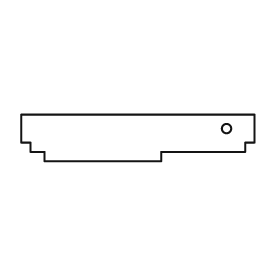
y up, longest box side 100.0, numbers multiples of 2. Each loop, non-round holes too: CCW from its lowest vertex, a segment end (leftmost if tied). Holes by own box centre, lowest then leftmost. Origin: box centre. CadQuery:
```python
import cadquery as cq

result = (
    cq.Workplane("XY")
    .moveTo(-40.0, -10.0)
    .lineTo(10.0, -10.0)
    .lineTo(10.0, -6.0)
    .lineTo(46.0, -6.0)
    .lineTo(46.0, -2.0)
    .lineTo(50.0, -2.0)
    .lineTo(50.0, 10.0)
    .lineTo(-50.0, 10.0)
    .lineTo(-50.0, -2.0)
    .lineTo(-46.0, -2.0)
    .lineTo(-46.0, -6.0)
    .lineTo(-40.0, -6.0)
    .close()
    .moveTo(38.0, 4.0)
    .circle(2.0)
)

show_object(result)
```